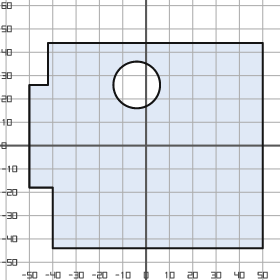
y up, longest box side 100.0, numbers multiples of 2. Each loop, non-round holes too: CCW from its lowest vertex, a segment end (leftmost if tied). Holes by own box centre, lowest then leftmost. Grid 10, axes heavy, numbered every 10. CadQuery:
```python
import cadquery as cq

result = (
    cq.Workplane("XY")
    .moveTo(-40.0, -44.0)
    .lineTo(50.0, -44.0)
    .lineTo(50.0, 44.0)
    .lineTo(-42.0, 44.0)
    .lineTo(-42.0, 26.0)
    .lineTo(-50.0, 26.0)
    .lineTo(-50.0, -18.0)
    .lineTo(-40.0, -18.0)
    .close()
    .moveTo(-4.0, 26.0)
    .circle(10.0)
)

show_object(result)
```